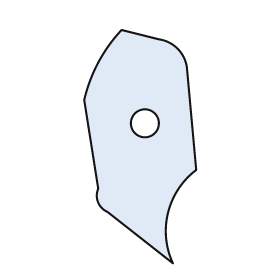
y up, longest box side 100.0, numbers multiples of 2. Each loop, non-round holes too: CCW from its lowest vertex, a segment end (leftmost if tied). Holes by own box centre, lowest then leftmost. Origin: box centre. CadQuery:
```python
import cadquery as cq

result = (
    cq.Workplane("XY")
    .moveTo(14.0, -50.0)
    .threePointArc((12.0, -28.0), (24.0, -10.0))
    .lineTo(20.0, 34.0)
    .threePointArc((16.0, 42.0), (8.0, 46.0))
    .lineTo(-8.0, 50.0)
    .threePointArc((-18.0, 36.0), (-24.0, 20.0))
    .lineTo(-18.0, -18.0)
    .threePointArc((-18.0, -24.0), (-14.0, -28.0))
    .close()
    .moveTo(2.0, 10.0)
    .circle(6.0)
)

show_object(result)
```